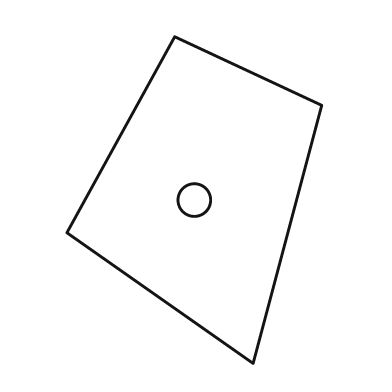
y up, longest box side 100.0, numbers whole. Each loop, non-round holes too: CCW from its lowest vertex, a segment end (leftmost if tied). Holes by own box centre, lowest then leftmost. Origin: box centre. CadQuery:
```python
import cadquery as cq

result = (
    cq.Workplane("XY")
    .moveTo(18.0, -50.0)
    .lineTo(39.0, 29.0)
    .lineTo(-6.0, 50.0)
    .lineTo(-39.0, -10.0)
    .close()
    .moveTo(0.0, 0.0)
    .circle(5.0)
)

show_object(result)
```